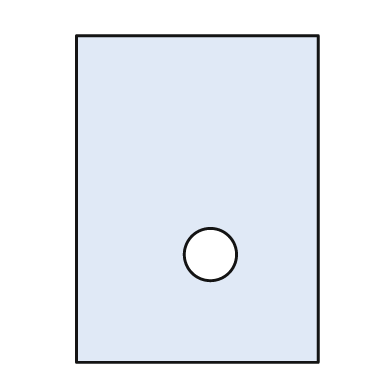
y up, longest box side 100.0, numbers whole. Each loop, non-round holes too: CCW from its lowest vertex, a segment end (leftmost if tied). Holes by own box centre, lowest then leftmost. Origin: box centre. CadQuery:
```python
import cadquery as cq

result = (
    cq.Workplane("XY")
    .moveTo(-37.0, -50.0)
    .lineTo(37.0, -50.0)
    .lineTo(37.0, 50.0)
    .lineTo(-37.0, 50.0)
    .close()
    .moveTo(4.0, -17.0)
    .circle(8.0)
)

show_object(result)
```